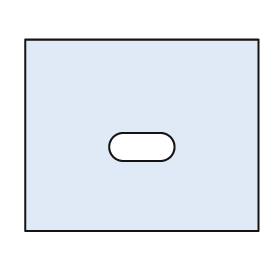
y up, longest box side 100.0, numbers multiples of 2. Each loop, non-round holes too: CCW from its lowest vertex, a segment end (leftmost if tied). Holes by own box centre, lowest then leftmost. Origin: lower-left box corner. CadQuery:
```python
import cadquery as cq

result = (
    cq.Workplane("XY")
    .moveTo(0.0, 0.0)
    .lineTo(100.0, 0.0)
    .lineTo(100.0, 82.0)
    .lineTo(0.0, 82.0)
    .close()
    .moveTo(42.0, 30.0)
    .lineTo(58.0, 30.0)
    .threePointArc((64.0, 36.0), (58.0, 42.0))
    .lineTo(42.0, 42.0)
    .threePointArc((36.0, 36.0), (42.0, 30.0))
    .close()
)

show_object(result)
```